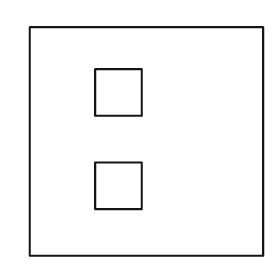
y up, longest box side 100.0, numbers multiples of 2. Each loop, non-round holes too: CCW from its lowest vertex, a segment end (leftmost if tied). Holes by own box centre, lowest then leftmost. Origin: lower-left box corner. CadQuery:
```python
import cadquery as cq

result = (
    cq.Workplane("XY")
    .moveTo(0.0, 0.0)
    .lineTo(100.0, 0.0)
    .lineTo(100.0, 98.0)
    .lineTo(0.0, 98.0)
    .close()
    .moveTo(28.0, 20.0)
    .lineTo(48.0, 20.0)
    .lineTo(48.0, 40.0)
    .lineTo(28.0, 40.0)
    .close()
    .moveTo(28.0, 60.0)
    .lineTo(48.0, 60.0)
    .lineTo(48.0, 80.0)
    .lineTo(28.0, 80.0)
    .close()
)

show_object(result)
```